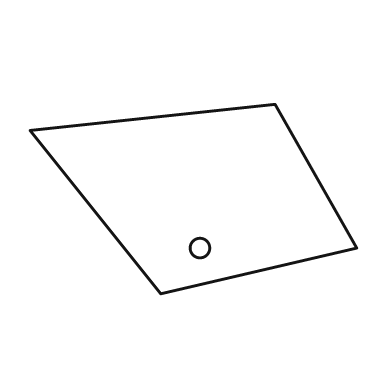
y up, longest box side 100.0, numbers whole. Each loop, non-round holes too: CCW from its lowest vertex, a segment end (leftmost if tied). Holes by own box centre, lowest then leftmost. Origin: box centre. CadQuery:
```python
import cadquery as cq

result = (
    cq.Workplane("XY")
    .moveTo(-10.0, -29.0)
    .lineTo(50.0, -15.0)
    .lineTo(25.0, 29.0)
    .lineTo(-50.0, 21.0)
    .close()
    .moveTo(2.0, -15.0)
    .circle(3.0)
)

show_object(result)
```